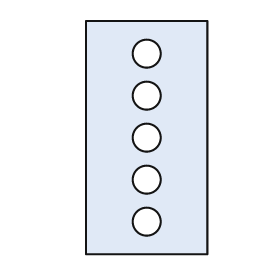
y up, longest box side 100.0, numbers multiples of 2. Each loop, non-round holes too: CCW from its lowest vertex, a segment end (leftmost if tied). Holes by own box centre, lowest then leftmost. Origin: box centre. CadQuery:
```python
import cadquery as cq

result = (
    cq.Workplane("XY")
    .moveTo(-26.0, -50.0)
    .lineTo(26.0, -50.0)
    .lineTo(26.0, 50.0)
    .lineTo(-26.0, 50.0)
    .close()
    .moveTo(0.0, -36.0)
    .circle(6.0)
    .moveTo(0.0, -18.0)
    .circle(6.0)
    .moveTo(0.0, 0.0)
    .circle(6.0)
    .moveTo(0.0, 18.0)
    .circle(6.0)
    .moveTo(0.0, 36.0)
    .circle(6.0)
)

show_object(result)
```